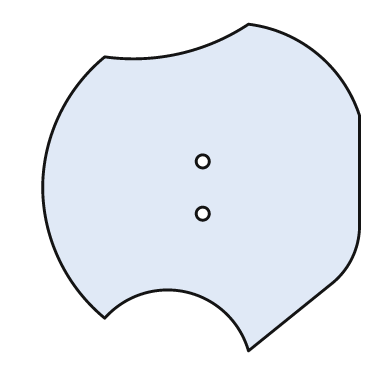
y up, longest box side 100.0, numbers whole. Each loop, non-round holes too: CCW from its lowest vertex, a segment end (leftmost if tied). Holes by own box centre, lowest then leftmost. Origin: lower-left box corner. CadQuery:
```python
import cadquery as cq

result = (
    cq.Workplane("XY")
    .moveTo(63.0, 0.0)
    .lineTo(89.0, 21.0)
    .threePointArc((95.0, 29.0), (97.0, 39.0))
    .lineTo(97.0, 72.0)
    .threePointArc((84.0, 91.0), (63.0, 100.0))
    .threePointArc((42.0, 91.0), (19.0, 90.0))
    .threePointArc((5.0, 72.0), (0.0, 50.0))
    .threePointArc((5.0, 28.0), (19.0, 10.0))
    .threePointArc((44.0, 18.0), (63.0, 0.0))
    .close()
    .moveTo(49.0, 42.0)
    .circle(2.0)
    .moveTo(49.0, 58.0)
    .circle(2.0)
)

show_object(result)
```